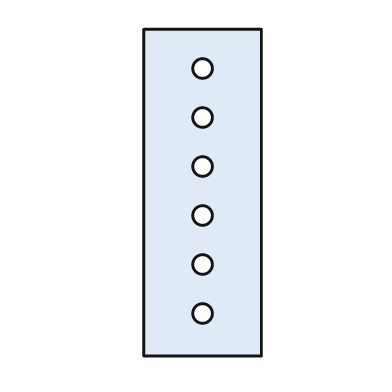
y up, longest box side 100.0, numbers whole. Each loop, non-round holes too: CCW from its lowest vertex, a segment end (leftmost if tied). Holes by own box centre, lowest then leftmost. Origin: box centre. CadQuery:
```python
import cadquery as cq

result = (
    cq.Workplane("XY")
    .moveTo(-18.0, -50.0)
    .lineTo(18.0, -50.0)
    .lineTo(18.0, 50.0)
    .lineTo(-18.0, 50.0)
    .close()
    .moveTo(0.0, -37.0)
    .circle(3.0)
    .moveTo(0.0, -22.0)
    .circle(3.0)
    .moveTo(0.0, -7.0)
    .circle(3.0)
    .moveTo(0.0, 8.0)
    .circle(3.0)
    .moveTo(0.0, 23.0)
    .circle(3.0)
    .moveTo(0.0, 38.0)
    .circle(3.0)
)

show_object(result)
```